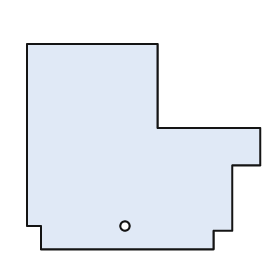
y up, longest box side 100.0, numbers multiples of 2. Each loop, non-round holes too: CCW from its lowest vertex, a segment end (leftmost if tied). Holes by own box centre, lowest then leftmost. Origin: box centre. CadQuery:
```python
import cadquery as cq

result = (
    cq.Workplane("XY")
    .moveTo(-44.0, -44.0)
    .lineTo(30.0, -44.0)
    .lineTo(30.0, -36.0)
    .lineTo(38.0, -36.0)
    .lineTo(38.0, -8.0)
    .lineTo(50.0, -8.0)
    .lineTo(50.0, 8.0)
    .lineTo(6.0, 8.0)
    .lineTo(6.0, 44.0)
    .lineTo(-50.0, 44.0)
    .lineTo(-50.0, -34.0)
    .lineTo(-44.0, -34.0)
    .close()
    .moveTo(-8.0, -34.0)
    .circle(2.0)
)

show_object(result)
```